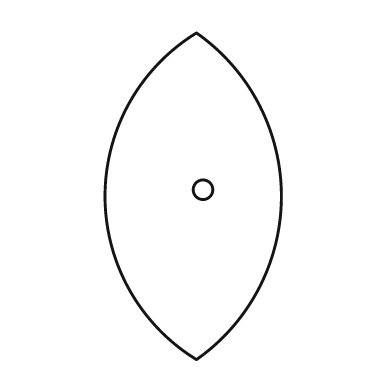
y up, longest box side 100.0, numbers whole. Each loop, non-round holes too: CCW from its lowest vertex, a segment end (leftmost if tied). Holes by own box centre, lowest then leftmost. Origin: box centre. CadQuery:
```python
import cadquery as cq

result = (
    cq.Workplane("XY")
    .moveTo(1.0, -50.0)
    .threePointArc((27.0, 0.0), (1.0, 50.0))
    .threePointArc((-27.0, 0.0), (1.0, -50.0))
    .close()
    .moveTo(3.0, 2.0)
    .circle(3.0)
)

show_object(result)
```